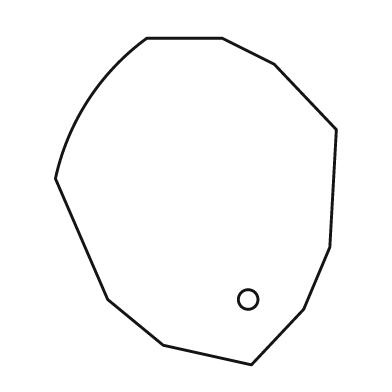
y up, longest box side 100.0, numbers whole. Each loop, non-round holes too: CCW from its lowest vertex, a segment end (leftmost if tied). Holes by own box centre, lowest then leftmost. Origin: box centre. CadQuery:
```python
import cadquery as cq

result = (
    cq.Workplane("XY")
    .moveTo(17.0, -50.0)
    .lineTo(33.0, -33.0)
    .lineTo(41.0, -14.0)
    .lineTo(43.0, 22.0)
    .lineTo(24.0, 42.0)
    .lineTo(8.0, 50.0)
    .lineTo(-15.0, 50.0)
    .threePointArc((-33.0, 31.0), (-43.0, 7.0))
    .lineTo(-27.0, -30.0)
    .lineTo(-10.0, -44.0)
    .close()
    .moveTo(16.0, -30.0)
    .circle(3.0)
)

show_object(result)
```